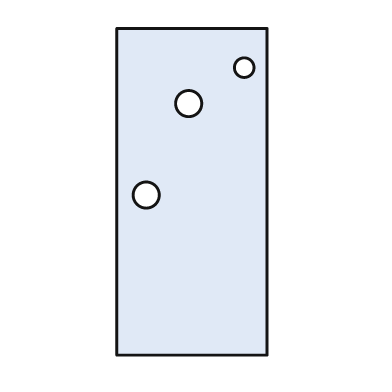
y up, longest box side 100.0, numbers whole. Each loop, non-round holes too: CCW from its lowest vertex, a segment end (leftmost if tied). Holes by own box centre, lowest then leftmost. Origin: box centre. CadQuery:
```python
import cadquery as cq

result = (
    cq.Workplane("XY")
    .moveTo(-23.0, -50.0)
    .lineTo(23.0, -50.0)
    .lineTo(23.0, 50.0)
    .lineTo(-23.0, 50.0)
    .close()
    .moveTo(-14.0, -1.0)
    .circle(4.0)
    .moveTo(-1.0, 27.0)
    .circle(4.0)
    .moveTo(16.0, 38.0)
    .circle(3.0)
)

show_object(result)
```